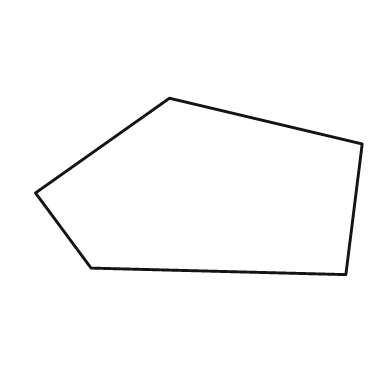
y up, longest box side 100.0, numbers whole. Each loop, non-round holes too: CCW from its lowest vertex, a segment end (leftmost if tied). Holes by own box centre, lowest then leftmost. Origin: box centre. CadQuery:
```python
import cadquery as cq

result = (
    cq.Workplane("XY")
    .moveTo(45.0, -27.0)
    .lineTo(50.0, 13.0)
    .lineTo(-9.0, 27.0)
    .lineTo(-50.0, -2.0)
    .lineTo(-33.0, -25.0)
    .close()
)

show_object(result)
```